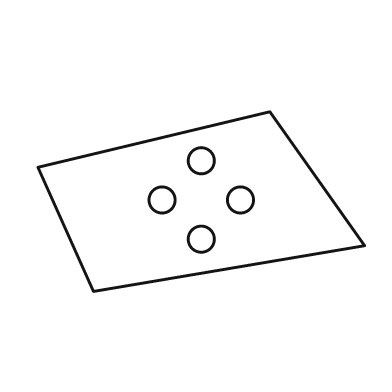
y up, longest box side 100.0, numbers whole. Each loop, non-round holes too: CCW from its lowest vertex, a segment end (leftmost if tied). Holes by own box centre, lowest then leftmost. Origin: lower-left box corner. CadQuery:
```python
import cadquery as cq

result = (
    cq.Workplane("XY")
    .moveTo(17.0, 0.0)
    .lineTo(100.0, 14.0)
    .lineTo(71.0, 55.0)
    .lineTo(0.0, 38.0)
    .close()
    .moveTo(50.0, 16.0)
    .circle(4.0)
    .moveTo(38.0, 28.0)
    .circle(4.0)
    .moveTo(62.0, 28.0)
    .circle(4.0)
    .moveTo(50.0, 40.0)
    .circle(4.0)
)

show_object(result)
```